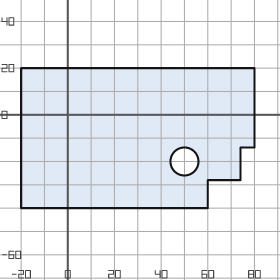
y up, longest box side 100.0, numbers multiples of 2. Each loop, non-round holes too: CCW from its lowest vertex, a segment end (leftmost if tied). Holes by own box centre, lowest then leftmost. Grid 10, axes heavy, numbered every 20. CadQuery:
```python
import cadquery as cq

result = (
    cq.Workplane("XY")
    .moveTo(-20.0, -40.0)
    .lineTo(60.0, -40.0)
    .lineTo(60.0, -28.0)
    .lineTo(74.0, -28.0)
    .lineTo(74.0, -14.0)
    .lineTo(80.0, -14.0)
    .lineTo(80.0, 20.0)
    .lineTo(-20.0, 20.0)
    .close()
    .moveTo(50.0, -20.0)
    .circle(6.0)
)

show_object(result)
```